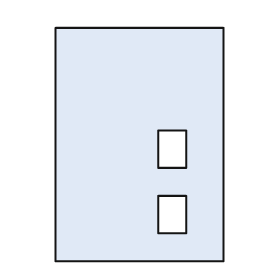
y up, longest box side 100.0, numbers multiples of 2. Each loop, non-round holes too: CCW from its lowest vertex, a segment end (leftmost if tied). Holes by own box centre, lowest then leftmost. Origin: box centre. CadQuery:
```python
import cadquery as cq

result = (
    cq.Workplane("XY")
    .moveTo(-36.0, -50.0)
    .lineTo(36.0, -50.0)
    .lineTo(36.0, 50.0)
    .lineTo(-36.0, 50.0)
    .close()
    .moveTo(8.0, -38.0)
    .lineTo(20.0, -38.0)
    .lineTo(20.0, -22.0)
    .lineTo(8.0, -22.0)
    .close()
    .moveTo(8.0, -10.0)
    .lineTo(20.0, -10.0)
    .lineTo(20.0, 6.0)
    .lineTo(8.0, 6.0)
    .close()
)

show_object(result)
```